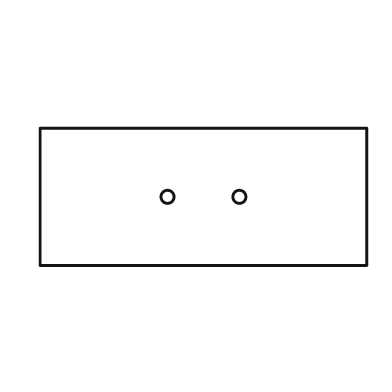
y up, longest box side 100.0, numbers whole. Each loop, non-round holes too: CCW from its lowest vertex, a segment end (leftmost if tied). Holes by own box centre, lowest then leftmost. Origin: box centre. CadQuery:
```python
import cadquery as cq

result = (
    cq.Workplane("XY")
    .moveTo(-50.0, -21.0)
    .lineTo(50.0, -21.0)
    .lineTo(50.0, 21.0)
    .lineTo(-50.0, 21.0)
    .close()
    .moveTo(-11.0, 0.0)
    .circle(2.0)
    .moveTo(11.0, 0.0)
    .circle(2.0)
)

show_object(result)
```